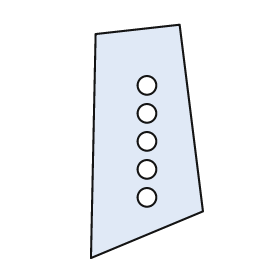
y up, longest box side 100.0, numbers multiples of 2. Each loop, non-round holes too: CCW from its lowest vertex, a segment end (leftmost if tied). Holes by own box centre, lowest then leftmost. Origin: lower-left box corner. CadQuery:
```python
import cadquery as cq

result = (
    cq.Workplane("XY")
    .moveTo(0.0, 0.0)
    .lineTo(48.0, 20.0)
    .lineTo(38.0, 100.0)
    .lineTo(2.0, 96.0)
    .close()
    .moveTo(24.0, 26.0)
    .circle(4.0)
    .moveTo(24.0, 38.0)
    .circle(4.0)
    .moveTo(24.0, 50.0)
    .circle(4.0)
    .moveTo(24.0, 62.0)
    .circle(4.0)
    .moveTo(24.0, 74.0)
    .circle(4.0)
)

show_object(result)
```